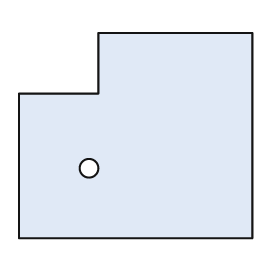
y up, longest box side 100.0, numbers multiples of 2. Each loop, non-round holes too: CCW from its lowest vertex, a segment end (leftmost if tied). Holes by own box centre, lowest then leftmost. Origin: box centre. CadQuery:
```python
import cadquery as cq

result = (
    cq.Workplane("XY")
    .moveTo(-50.0, -44.0)
    .lineTo(50.0, -44.0)
    .lineTo(50.0, 44.0)
    .lineTo(-16.0, 44.0)
    .lineTo(-16.0, 18.0)
    .lineTo(-50.0, 18.0)
    .close()
    .moveTo(-20.0, -14.0)
    .circle(4.0)
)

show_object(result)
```